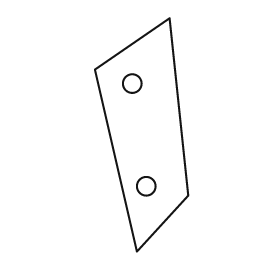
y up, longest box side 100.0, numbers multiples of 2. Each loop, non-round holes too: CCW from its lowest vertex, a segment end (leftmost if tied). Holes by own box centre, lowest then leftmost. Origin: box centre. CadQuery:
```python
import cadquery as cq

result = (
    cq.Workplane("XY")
    .moveTo(-2.0, -50.0)
    .lineTo(20.0, -26.0)
    .lineTo(12.0, 50.0)
    .lineTo(-20.0, 28.0)
    .close()
    .moveTo(2.0, -22.0)
    .circle(4.0)
    .moveTo(-4.0, 22.0)
    .circle(4.0)
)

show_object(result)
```